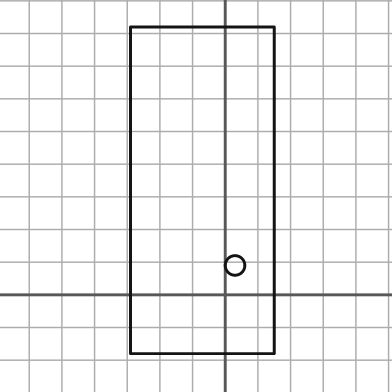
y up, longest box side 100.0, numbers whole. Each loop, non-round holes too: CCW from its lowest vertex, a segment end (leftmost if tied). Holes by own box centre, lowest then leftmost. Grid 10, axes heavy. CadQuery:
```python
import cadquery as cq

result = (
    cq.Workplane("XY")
    .moveTo(-29.0, -18.0)
    .lineTo(15.0, -18.0)
    .lineTo(15.0, 82.0)
    .lineTo(-29.0, 82.0)
    .close()
    .moveTo(3.0, 9.0)
    .circle(3.0)
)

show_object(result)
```